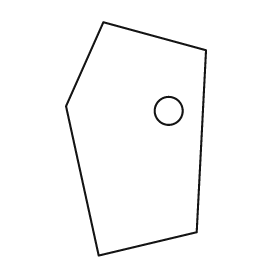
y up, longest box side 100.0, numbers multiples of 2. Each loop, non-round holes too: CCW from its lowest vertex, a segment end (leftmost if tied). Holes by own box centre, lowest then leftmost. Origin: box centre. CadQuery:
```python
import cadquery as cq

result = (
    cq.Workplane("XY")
    .moveTo(-16.0, -50.0)
    .lineTo(26.0, -40.0)
    .lineTo(30.0, 38.0)
    .lineTo(-14.0, 50.0)
    .lineTo(-30.0, 14.0)
    .close()
    .moveTo(14.0, 12.0)
    .circle(6.0)
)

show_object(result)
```